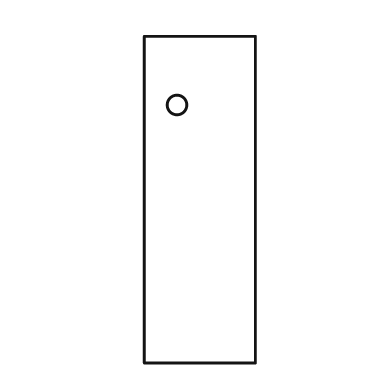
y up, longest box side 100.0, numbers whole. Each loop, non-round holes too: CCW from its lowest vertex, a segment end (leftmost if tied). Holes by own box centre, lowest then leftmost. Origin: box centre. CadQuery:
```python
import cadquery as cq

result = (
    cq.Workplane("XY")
    .moveTo(-17.0, -50.0)
    .lineTo(17.0, -50.0)
    .lineTo(17.0, 50.0)
    .lineTo(-17.0, 50.0)
    .close()
    .moveTo(-7.0, 29.0)
    .circle(3.0)
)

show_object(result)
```